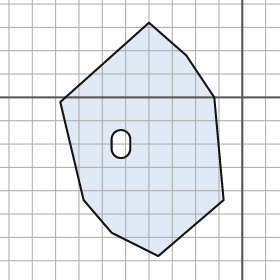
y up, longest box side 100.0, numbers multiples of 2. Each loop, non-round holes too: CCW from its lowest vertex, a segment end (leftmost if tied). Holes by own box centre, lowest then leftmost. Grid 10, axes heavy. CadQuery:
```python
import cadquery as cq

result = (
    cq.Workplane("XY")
    .moveTo(-36.0, -68.0)
    .lineTo(-8.0, -44.0)
    .lineTo(-12.0, 0.0)
    .lineTo(-24.0, 18.0)
    .lineTo(-40.0, 32.0)
    .lineTo(-78.0, -2.0)
    .lineTo(-68.0, -44.0)
    .lineTo(-56.0, -58.0)
    .close()
    .moveTo(-56.0, -22.0)
    .threePointArc((-52.0, -26.0), (-48.0, -22.0))
    .lineTo(-48.0, -18.0)
    .threePointArc((-52.0, -14.0), (-56.0, -18.0))
    .close()
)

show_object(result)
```